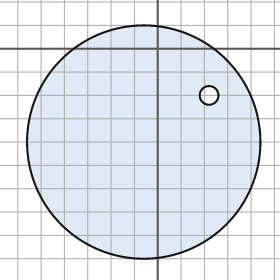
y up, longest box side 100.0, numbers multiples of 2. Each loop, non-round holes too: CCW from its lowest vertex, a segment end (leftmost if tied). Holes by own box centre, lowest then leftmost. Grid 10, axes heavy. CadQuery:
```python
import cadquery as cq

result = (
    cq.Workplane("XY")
    .moveTo(-6.0, -40.0)
    .circle(50.0)
    .moveTo(22.0, -20.0)
    .circle(4.0)
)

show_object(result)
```